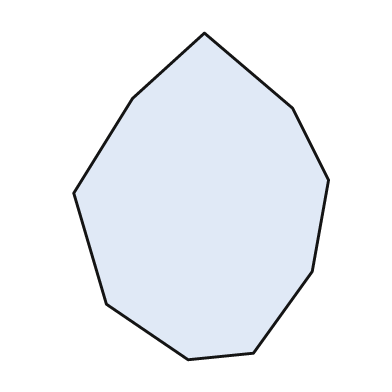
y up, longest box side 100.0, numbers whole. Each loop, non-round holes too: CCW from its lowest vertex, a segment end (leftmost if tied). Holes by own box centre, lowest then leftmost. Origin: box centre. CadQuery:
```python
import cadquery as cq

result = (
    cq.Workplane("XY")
    .moveTo(-4.0, -50.0)
    .lineTo(16.0, -48.0)
    .lineTo(34.0, -23.0)
    .lineTo(39.0, 5.0)
    .lineTo(28.0, 27.0)
    .lineTo(1.0, 50.0)
    .lineTo(-21.0, 30.0)
    .lineTo(-39.0, 1.0)
    .lineTo(-29.0, -33.0)
    .close()
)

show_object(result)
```